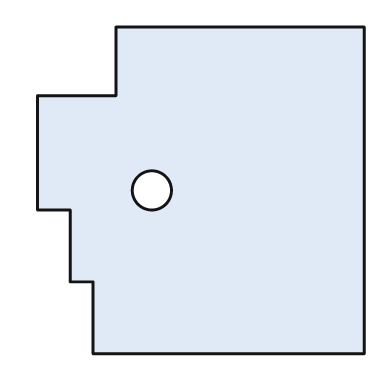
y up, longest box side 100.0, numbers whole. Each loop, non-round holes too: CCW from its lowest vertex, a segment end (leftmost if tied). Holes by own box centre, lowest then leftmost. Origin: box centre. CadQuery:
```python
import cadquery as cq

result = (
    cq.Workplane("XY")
    .moveTo(-33.0, -50.0)
    .lineTo(50.0, -50.0)
    .lineTo(50.0, 50.0)
    .lineTo(-26.0, 50.0)
    .lineTo(-26.0, 29.0)
    .lineTo(-50.0, 29.0)
    .lineTo(-50.0, -6.0)
    .lineTo(-40.0, -6.0)
    .lineTo(-40.0, -28.0)
    .lineTo(-33.0, -28.0)
    .close()
    .moveTo(-15.0, 0.0)
    .circle(6.0)
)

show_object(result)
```